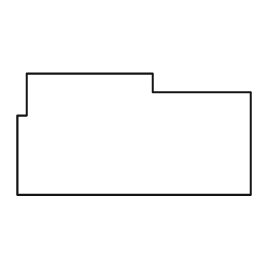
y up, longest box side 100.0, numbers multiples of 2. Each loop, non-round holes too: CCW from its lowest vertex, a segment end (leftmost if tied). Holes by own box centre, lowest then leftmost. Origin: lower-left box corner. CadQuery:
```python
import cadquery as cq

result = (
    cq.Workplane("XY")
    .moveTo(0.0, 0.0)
    .lineTo(100.0, 0.0)
    .lineTo(100.0, 44.0)
    .lineTo(58.0, 44.0)
    .lineTo(58.0, 52.0)
    .lineTo(4.0, 52.0)
    .lineTo(4.0, 34.0)
    .lineTo(0.0, 34.0)
    .close()
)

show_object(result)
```